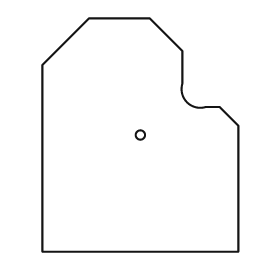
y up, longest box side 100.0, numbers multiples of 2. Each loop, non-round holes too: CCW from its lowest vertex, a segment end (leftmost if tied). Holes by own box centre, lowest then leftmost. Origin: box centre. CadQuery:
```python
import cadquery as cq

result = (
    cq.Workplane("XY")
    .moveTo(-42.0, -50.0)
    .lineTo(42.0, -50.0)
    .lineTo(42.0, 4.0)
    .lineTo(34.0, 12.0)
    .lineTo(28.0, 12.0)
    .threePointArc((20.0, 14.0), (18.0, 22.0))
    .lineTo(18.0, 36.0)
    .lineTo(4.0, 50.0)
    .lineTo(-22.0, 50.0)
    .lineTo(-42.0, 30.0)
    .close()
    .moveTo(0.0, 0.0)
    .circle(2.0)
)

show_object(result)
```